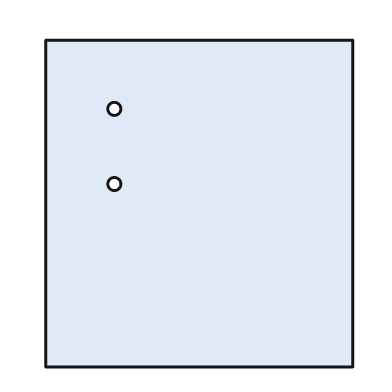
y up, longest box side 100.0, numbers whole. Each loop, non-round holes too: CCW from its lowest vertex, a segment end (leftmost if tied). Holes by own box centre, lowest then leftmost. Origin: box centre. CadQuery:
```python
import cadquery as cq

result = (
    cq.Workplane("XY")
    .moveTo(-47.0, -50.0)
    .lineTo(47.0, -50.0)
    .lineTo(47.0, 50.0)
    .lineTo(-47.0, 50.0)
    .close()
    .moveTo(-26.0, 6.0)
    .circle(2.0)
    .moveTo(-26.0, 29.0)
    .circle(2.0)
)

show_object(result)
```